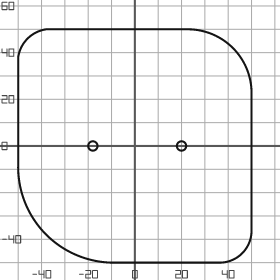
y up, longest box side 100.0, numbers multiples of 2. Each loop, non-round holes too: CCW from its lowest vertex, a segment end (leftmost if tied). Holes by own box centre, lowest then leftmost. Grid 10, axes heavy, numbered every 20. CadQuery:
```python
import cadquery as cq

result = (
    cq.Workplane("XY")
    .moveTo(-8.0, -50.0)
    .lineTo(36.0, -50.0)
    .threePointArc((46.0, -46.0), (50.0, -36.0))
    .lineTo(50.0, 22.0)
    .threePointArc((42.0, 42.0), (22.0, 50.0))
    .lineTo(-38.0, 50.0)
    .threePointArc((-46.0, 46.0), (-50.0, 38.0))
    .lineTo(-50.0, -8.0)
    .threePointArc((-38.0, -38.0), (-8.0, -50.0))
    .close()
    .moveTo(-18.0, 0.0)
    .circle(2.0)
    .moveTo(20.0, 0.0)
    .circle(2.0)
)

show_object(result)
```